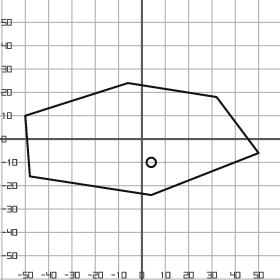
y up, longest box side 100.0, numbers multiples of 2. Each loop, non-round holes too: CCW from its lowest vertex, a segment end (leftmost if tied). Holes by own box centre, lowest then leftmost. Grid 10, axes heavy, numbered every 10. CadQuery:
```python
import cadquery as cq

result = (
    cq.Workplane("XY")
    .moveTo(4.0, -24.0)
    .lineTo(50.0, -6.0)
    .lineTo(32.0, 18.0)
    .lineTo(-6.0, 24.0)
    .lineTo(-50.0, 10.0)
    .lineTo(-48.0, -16.0)
    .close()
    .moveTo(4.0, -10.0)
    .circle(2.0)
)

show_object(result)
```